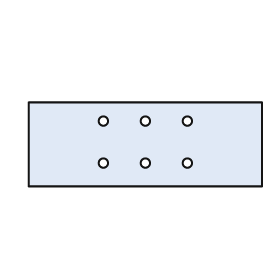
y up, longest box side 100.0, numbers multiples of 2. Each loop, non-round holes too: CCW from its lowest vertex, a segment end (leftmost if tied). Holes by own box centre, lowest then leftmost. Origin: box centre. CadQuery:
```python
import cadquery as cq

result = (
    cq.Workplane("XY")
    .moveTo(-50.0, -18.0)
    .lineTo(50.0, -18.0)
    .lineTo(50.0, 18.0)
    .lineTo(-50.0, 18.0)
    .close()
    .moveTo(-18.0, -8.0)
    .circle(2.0)
    .moveTo(0.0, -8.0)
    .circle(2.0)
    .moveTo(18.0, -8.0)
    .circle(2.0)
    .moveTo(-18.0, 10.0)
    .circle(2.0)
    .moveTo(0.0, 10.0)
    .circle(2.0)
    .moveTo(18.0, 10.0)
    .circle(2.0)
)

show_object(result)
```